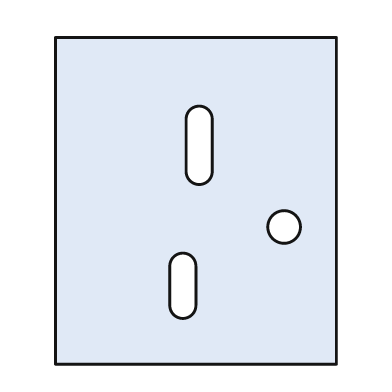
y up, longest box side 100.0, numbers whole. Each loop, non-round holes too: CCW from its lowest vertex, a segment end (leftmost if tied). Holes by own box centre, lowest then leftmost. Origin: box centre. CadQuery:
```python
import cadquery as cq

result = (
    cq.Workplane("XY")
    .moveTo(-43.0, -50.0)
    .lineTo(43.0, -50.0)
    .lineTo(43.0, 50.0)
    .lineTo(-43.0, 50.0)
    .close()
    .moveTo(-8.0, -32.0)
    .threePointArc((-4.0, -36.0), (0.0, -32.0))
    .lineTo(0.0, -20.0)
    .threePointArc((-4.0, -16.0), (-8.0, -20.0))
    .close()
    .moveTo(27.0, -8.0)
    .circle(5.0)
    .moveTo(-3.0, 9.0)
    .threePointArc((1.0, 5.0), (5.0, 9.0))
    .lineTo(5.0, 25.0)
    .threePointArc((1.0, 29.0), (-3.0, 25.0))
    .close()
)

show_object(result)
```